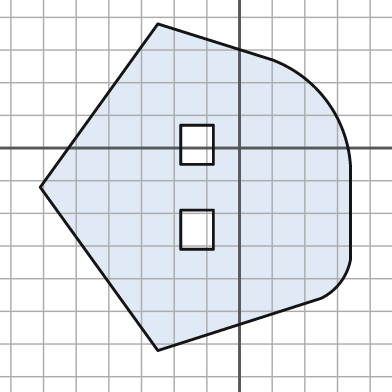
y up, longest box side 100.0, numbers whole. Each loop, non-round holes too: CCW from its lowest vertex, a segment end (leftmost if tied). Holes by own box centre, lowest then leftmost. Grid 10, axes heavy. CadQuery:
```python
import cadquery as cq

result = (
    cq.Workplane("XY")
    .moveTo(-25.0, -62.0)
    .lineTo(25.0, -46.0)
    .threePointArc((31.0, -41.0), (34.0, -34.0))
    .lineTo(34.0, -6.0)
    .threePointArc((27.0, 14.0), (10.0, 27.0))
    .lineTo(-25.0, 38.0)
    .lineTo(-61.0, -12.0)
    .close()
    .moveTo(-18.0, -31.0)
    .lineTo(-8.0, -31.0)
    .lineTo(-8.0, -19.0)
    .lineTo(-18.0, -19.0)
    .close()
    .moveTo(-18.0, -5.0)
    .lineTo(-8.0, -5.0)
    .lineTo(-8.0, 7.0)
    .lineTo(-18.0, 7.0)
    .close()
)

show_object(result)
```